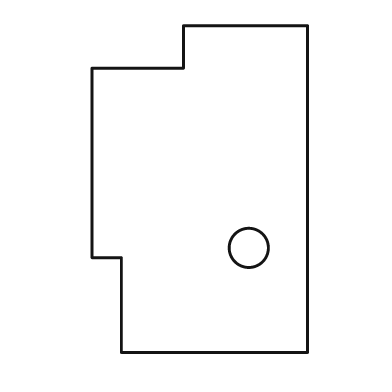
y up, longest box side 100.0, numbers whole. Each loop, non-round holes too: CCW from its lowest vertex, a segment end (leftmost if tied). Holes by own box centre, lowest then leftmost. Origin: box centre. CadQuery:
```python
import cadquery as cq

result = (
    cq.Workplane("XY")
    .moveTo(-24.0, -50.0)
    .lineTo(33.0, -50.0)
    .lineTo(33.0, 50.0)
    .lineTo(-5.0, 50.0)
    .lineTo(-5.0, 37.0)
    .lineTo(-33.0, 37.0)
    .lineTo(-33.0, -21.0)
    .lineTo(-24.0, -21.0)
    .close()
    .moveTo(15.0, -18.0)
    .circle(6.0)
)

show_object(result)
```